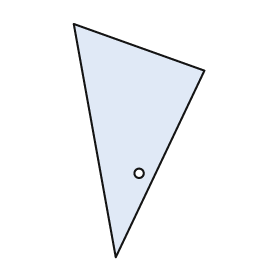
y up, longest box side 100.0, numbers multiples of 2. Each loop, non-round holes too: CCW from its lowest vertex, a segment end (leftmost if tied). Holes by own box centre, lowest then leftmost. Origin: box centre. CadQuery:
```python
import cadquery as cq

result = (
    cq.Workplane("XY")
    .moveTo(-10.0, -50.0)
    .lineTo(28.0, 30.0)
    .lineTo(-28.0, 50.0)
    .close()
    .moveTo(0.0, -14.0)
    .circle(2.0)
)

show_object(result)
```